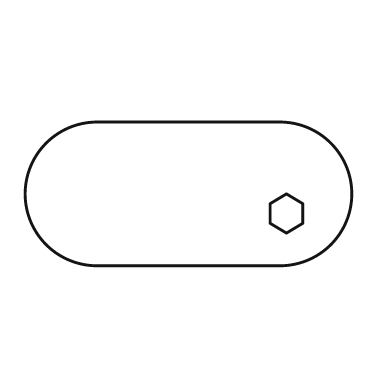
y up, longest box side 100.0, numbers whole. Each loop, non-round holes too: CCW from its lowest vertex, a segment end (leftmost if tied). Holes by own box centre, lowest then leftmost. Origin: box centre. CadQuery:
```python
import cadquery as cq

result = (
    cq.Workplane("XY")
    .moveTo(-28.0, -22.0)
    .lineTo(28.0, -22.0)
    .threePointArc((50.0, 0.0), (28.0, 22.0))
    .lineTo(-28.0, 22.0)
    .threePointArc((-50.0, 0.0), (-28.0, -22.0))
    .close()
    .moveTo(30.0, -12.0)
    .lineTo(35.0, -9.0)
    .lineTo(35.0, -3.0)
    .lineTo(30.0, 0.0)
    .lineTo(25.0, -3.0)
    .lineTo(25.0, -9.0)
    .close()
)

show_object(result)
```